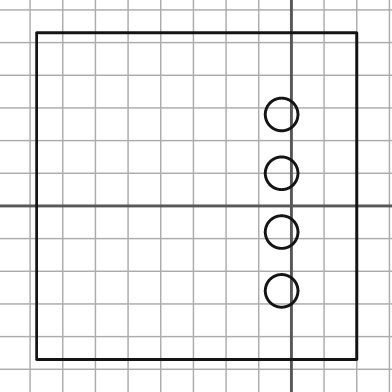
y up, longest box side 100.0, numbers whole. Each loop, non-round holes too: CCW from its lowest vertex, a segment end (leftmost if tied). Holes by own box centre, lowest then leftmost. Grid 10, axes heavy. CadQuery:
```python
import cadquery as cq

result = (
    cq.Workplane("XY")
    .moveTo(-78.0, -47.0)
    .lineTo(20.0, -47.0)
    .lineTo(20.0, 53.0)
    .lineTo(-78.0, 53.0)
    .close()
    .moveTo(-3.0, -26.0)
    .circle(5.0)
    .moveTo(-3.0, -8.0)
    .circle(5.0)
    .moveTo(-3.0, 10.0)
    .circle(5.0)
    .moveTo(-3.0, 28.0)
    .circle(5.0)
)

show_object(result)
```